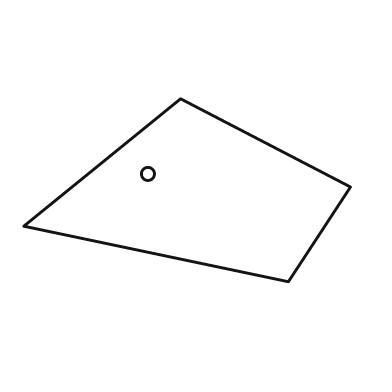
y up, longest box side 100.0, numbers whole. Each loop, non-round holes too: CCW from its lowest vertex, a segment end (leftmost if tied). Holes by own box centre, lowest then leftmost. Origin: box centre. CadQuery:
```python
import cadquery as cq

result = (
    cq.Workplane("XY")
    .moveTo(31.0, -28.0)
    .lineTo(50.0, 1.0)
    .lineTo(-2.0, 28.0)
    .lineTo(-50.0, -11.0)
    .close()
    .moveTo(-12.0, 5.0)
    .circle(2.0)
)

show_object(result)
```